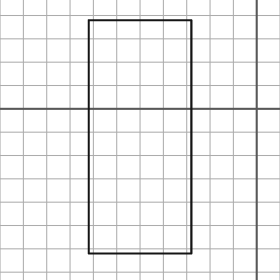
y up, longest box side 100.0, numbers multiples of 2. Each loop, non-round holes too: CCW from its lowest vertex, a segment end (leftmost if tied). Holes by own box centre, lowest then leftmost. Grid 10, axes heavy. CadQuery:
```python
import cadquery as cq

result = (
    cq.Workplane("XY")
    .moveTo(-72.0, -62.0)
    .lineTo(-28.0, -62.0)
    .lineTo(-28.0, 38.0)
    .lineTo(-72.0, 38.0)
    .close()
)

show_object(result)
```